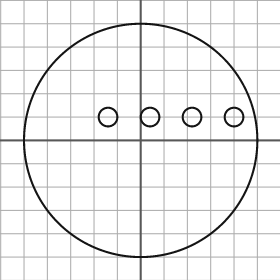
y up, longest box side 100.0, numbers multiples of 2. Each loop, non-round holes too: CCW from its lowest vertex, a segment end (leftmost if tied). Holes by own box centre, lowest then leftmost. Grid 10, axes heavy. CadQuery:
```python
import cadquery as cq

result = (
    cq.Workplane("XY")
    .moveTo(0.0, 0.0)
    .circle(50.0)
    .moveTo(-14.0, 10.0)
    .circle(4.0)
    .moveTo(4.0, 10.0)
    .circle(4.0)
    .moveTo(22.0, 10.0)
    .circle(4.0)
    .moveTo(40.0, 10.0)
    .circle(4.0)
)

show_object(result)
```